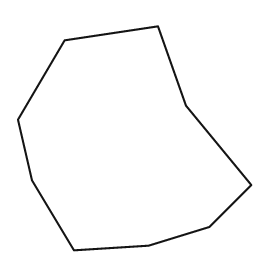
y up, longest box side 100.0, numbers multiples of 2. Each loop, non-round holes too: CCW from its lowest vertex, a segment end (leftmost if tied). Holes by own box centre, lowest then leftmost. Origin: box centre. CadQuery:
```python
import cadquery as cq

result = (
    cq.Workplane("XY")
    .moveTo(-26.0, -48.0)
    .lineTo(6.0, -46.0)
    .lineTo(32.0, -38.0)
    .lineTo(50.0, -20.0)
    .lineTo(22.0, 14.0)
    .lineTo(10.0, 48.0)
    .lineTo(-30.0, 42.0)
    .lineTo(-50.0, 8.0)
    .lineTo(-44.0, -18.0)
    .close()
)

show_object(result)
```